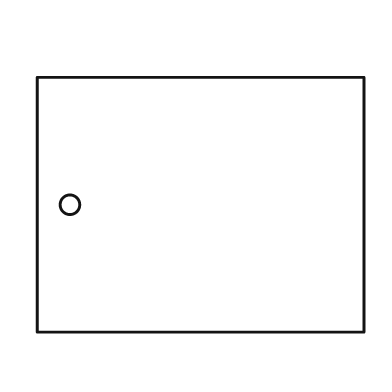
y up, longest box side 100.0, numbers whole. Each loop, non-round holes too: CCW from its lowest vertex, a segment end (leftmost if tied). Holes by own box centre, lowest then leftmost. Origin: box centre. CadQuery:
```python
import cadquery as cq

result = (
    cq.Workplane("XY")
    .moveTo(-50.0, -39.0)
    .lineTo(50.0, -39.0)
    .lineTo(50.0, 39.0)
    .lineTo(-50.0, 39.0)
    .close()
    .moveTo(-40.0, 0.0)
    .circle(3.0)
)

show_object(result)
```